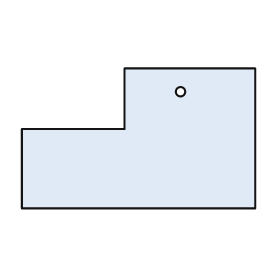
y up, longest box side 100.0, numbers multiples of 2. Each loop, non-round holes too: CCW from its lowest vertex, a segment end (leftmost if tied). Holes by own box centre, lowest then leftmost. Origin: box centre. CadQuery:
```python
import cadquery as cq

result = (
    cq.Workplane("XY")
    .moveTo(-50.0, -30.0)
    .lineTo(50.0, -30.0)
    .lineTo(50.0, 30.0)
    .lineTo(-6.0, 30.0)
    .lineTo(-6.0, 4.0)
    .lineTo(-50.0, 4.0)
    .close()
    .moveTo(18.0, 20.0)
    .circle(2.0)
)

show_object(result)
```